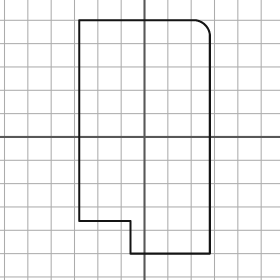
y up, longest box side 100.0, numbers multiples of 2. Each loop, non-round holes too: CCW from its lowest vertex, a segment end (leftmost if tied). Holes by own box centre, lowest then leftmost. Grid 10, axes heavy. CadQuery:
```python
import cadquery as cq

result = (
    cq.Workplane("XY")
    .moveTo(-6.0, -50.0)
    .lineTo(28.0, -50.0)
    .lineTo(28.0, 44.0)
    .threePointArc((26.0, 48.0), (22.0, 50.0))
    .lineTo(-28.0, 50.0)
    .lineTo(-28.0, -36.0)
    .lineTo(-6.0, -36.0)
    .close()
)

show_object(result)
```